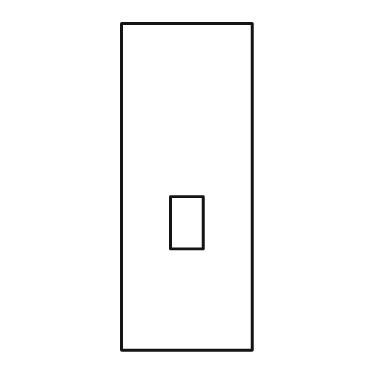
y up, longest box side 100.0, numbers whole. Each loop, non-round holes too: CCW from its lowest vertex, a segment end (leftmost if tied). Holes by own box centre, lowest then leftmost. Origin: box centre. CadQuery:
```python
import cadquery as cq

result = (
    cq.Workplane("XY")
    .moveTo(-20.0, -50.0)
    .lineTo(20.0, -50.0)
    .lineTo(20.0, 50.0)
    .lineTo(-20.0, 50.0)
    .close()
    .moveTo(-5.0, -19.0)
    .lineTo(5.0, -19.0)
    .lineTo(5.0, -3.0)
    .lineTo(-5.0, -3.0)
    .close()
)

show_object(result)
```